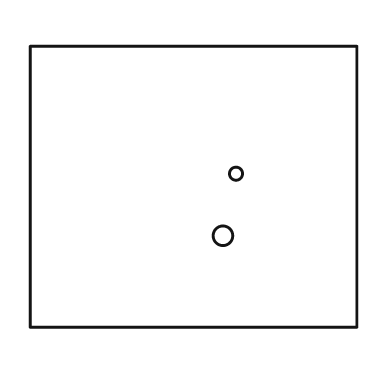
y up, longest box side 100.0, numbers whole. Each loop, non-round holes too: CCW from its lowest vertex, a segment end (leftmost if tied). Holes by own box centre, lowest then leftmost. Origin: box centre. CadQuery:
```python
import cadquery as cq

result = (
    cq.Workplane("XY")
    .moveTo(-50.0, -43.0)
    .lineTo(50.0, -43.0)
    .lineTo(50.0, 43.0)
    .lineTo(-50.0, 43.0)
    .close()
    .moveTo(9.0, -15.0)
    .circle(3.0)
    .moveTo(13.0, 4.0)
    .circle(2.0)
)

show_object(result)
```